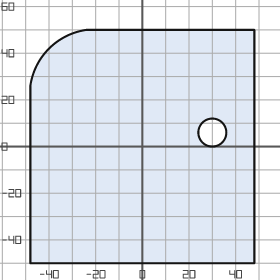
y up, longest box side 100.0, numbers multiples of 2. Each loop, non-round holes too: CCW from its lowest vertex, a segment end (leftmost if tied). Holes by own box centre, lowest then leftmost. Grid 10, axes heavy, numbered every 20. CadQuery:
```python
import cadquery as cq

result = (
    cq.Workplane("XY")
    .moveTo(-48.0, -50.0)
    .lineTo(48.0, -50.0)
    .lineTo(48.0, 50.0)
    .lineTo(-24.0, 50.0)
    .threePointArc((-40.0, 42.0), (-48.0, 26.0))
    .close()
    .moveTo(30.0, 6.0)
    .circle(6.0)
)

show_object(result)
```